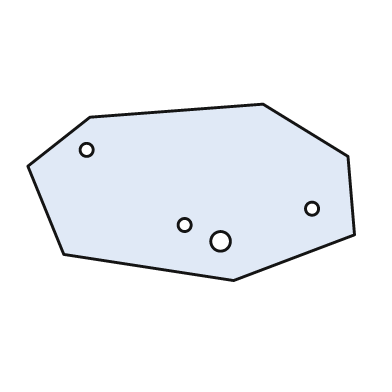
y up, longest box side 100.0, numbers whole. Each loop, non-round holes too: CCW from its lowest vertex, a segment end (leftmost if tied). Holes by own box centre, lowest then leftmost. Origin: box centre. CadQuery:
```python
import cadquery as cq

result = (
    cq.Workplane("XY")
    .moveTo(13.0, -27.0)
    .lineTo(50.0, -13.0)
    .lineTo(48.0, 11.0)
    .lineTo(22.0, 27.0)
    .lineTo(-31.0, 23.0)
    .lineTo(-50.0, 8.0)
    .lineTo(-39.0, -19.0)
    .close()
    .moveTo(9.0, -15.0)
    .circle(3.0)
    .moveTo(-2.0, -10.0)
    .circle(2.0)
    .moveTo(37.0, -5.0)
    .circle(2.0)
    .moveTo(-32.0, 13.0)
    .circle(2.0)
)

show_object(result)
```